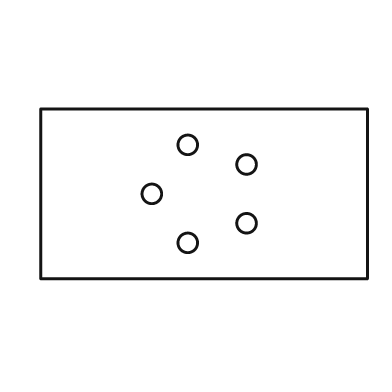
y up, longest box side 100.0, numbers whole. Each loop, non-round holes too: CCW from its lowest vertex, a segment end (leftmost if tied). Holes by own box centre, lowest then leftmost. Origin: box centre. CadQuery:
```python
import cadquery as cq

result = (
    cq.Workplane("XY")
    .moveTo(-50.0, -26.0)
    .lineTo(50.0, -26.0)
    .lineTo(50.0, 26.0)
    .lineTo(-50.0, 26.0)
    .close()
    .moveTo(-5.0, -15.0)
    .circle(3.0)
    .moveTo(13.0, -9.0)
    .circle(3.0)
    .moveTo(-16.0, 0.0)
    .circle(3.0)
    .moveTo(13.0, 9.0)
    .circle(3.0)
    .moveTo(-5.0, 15.0)
    .circle(3.0)
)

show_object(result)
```